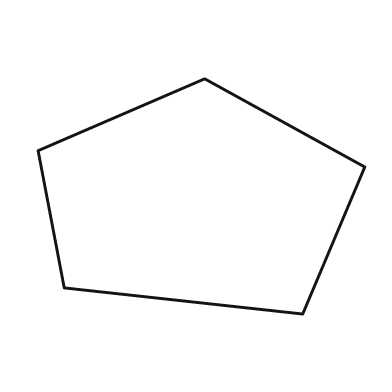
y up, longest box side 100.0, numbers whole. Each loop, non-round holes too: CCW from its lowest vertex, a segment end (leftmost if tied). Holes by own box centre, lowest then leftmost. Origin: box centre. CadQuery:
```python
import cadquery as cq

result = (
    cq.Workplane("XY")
    .moveTo(31.0, -36.0)
    .lineTo(50.0, 9.0)
    .lineTo(1.0, 36.0)
    .lineTo(-50.0, 14.0)
    .lineTo(-42.0, -28.0)
    .close()
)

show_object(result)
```